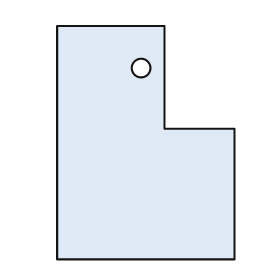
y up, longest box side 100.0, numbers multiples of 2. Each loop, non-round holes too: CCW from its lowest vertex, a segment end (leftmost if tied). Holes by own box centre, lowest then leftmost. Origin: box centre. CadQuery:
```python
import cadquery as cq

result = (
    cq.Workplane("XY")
    .moveTo(-38.0, -50.0)
    .lineTo(38.0, -50.0)
    .lineTo(38.0, 6.0)
    .lineTo(8.0, 6.0)
    .lineTo(8.0, 50.0)
    .lineTo(-38.0, 50.0)
    .close()
    .moveTo(-2.0, 32.0)
    .circle(4.0)
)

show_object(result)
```